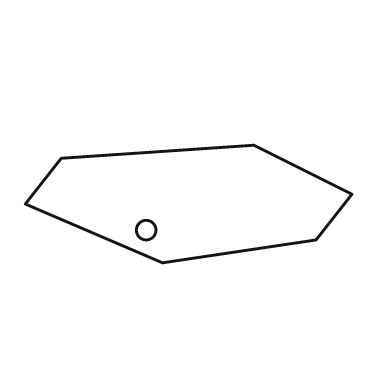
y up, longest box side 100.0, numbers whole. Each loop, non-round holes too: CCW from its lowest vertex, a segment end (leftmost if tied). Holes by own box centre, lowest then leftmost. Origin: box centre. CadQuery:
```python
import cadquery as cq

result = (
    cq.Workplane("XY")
    .moveTo(-8.0, -18.0)
    .lineTo(39.0, -11.0)
    .lineTo(50.0, 3.0)
    .lineTo(20.0, 18.0)
    .lineTo(-39.0, 14.0)
    .lineTo(-50.0, 0.0)
    .close()
    .moveTo(-13.0, -8.0)
    .circle(3.0)
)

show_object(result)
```